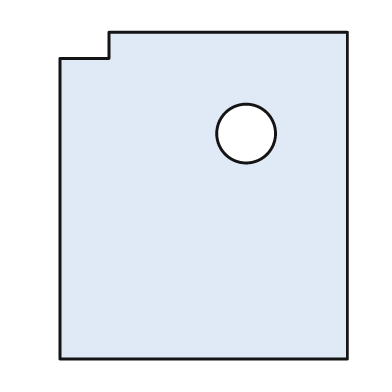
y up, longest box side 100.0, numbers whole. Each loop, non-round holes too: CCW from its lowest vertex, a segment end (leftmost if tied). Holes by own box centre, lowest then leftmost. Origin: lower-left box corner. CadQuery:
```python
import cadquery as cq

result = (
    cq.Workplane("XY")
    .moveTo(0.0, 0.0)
    .lineTo(88.0, 0.0)
    .lineTo(88.0, 100.0)
    .lineTo(15.0, 100.0)
    .lineTo(15.0, 92.0)
    .lineTo(0.0, 92.0)
    .close()
    .moveTo(57.0, 69.0)
    .circle(9.0)
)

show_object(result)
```